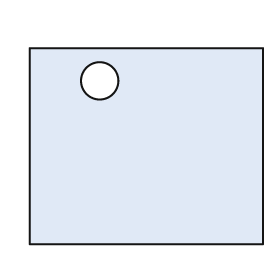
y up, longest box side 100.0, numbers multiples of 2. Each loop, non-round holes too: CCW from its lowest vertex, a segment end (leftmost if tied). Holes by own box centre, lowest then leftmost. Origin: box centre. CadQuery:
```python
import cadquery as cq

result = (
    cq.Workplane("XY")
    .moveTo(-50.0, -42.0)
    .lineTo(50.0, -42.0)
    .lineTo(50.0, 42.0)
    .lineTo(-50.0, 42.0)
    .close()
    .moveTo(-20.0, 28.0)
    .circle(8.0)
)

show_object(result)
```